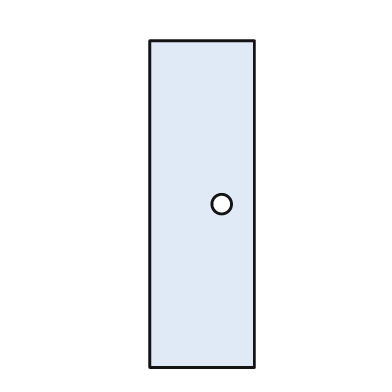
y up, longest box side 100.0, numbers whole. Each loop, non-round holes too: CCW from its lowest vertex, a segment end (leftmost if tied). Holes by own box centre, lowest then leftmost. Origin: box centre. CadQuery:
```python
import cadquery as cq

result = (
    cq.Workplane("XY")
    .moveTo(-16.0, -50.0)
    .lineTo(16.0, -50.0)
    .lineTo(16.0, 50.0)
    .lineTo(-16.0, 50.0)
    .close()
    .moveTo(6.0, 0.0)
    .circle(3.0)
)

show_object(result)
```